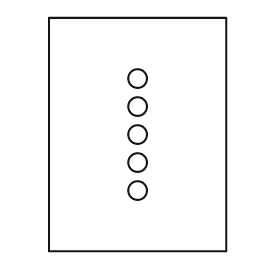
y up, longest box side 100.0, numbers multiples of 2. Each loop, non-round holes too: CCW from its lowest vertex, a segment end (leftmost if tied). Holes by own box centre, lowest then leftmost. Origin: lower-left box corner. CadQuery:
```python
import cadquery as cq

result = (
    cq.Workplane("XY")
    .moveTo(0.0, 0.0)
    .lineTo(76.0, 0.0)
    .lineTo(76.0, 100.0)
    .lineTo(0.0, 100.0)
    .close()
    .moveTo(38.0, 26.0)
    .circle(4.0)
    .moveTo(38.0, 38.0)
    .circle(4.0)
    .moveTo(38.0, 50.0)
    .circle(4.0)
    .moveTo(38.0, 62.0)
    .circle(4.0)
    .moveTo(38.0, 74.0)
    .circle(4.0)
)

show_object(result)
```